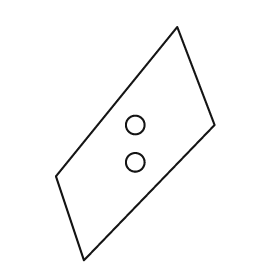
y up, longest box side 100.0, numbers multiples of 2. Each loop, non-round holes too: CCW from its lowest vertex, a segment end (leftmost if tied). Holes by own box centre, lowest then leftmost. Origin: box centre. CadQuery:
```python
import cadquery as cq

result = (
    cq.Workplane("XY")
    .moveTo(-22.0, -50.0)
    .lineTo(34.0, 8.0)
    .lineTo(18.0, 50.0)
    .lineTo(-34.0, -14.0)
    .close()
    .moveTo(0.0, -8.0)
    .circle(4.0)
    .moveTo(0.0, 8.0)
    .circle(4.0)
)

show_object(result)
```